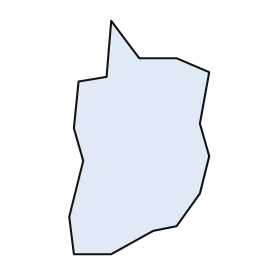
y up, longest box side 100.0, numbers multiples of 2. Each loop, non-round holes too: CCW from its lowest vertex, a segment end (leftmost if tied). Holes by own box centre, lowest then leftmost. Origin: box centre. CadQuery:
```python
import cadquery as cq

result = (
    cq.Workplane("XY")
    .moveTo(-28.0, -50.0)
    .lineTo(-12.0, -50.0)
    .lineTo(6.0, -40.0)
    .lineTo(16.0, -38.0)
    .lineTo(26.0, -24.0)
    .lineTo(30.0, -8.0)
    .lineTo(26.0, 6.0)
    .lineTo(30.0, 28.0)
    .lineTo(16.0, 34.0)
    .lineTo(0.0, 34.0)
    .lineTo(-12.0, 50.0)
    .lineTo(-14.0, 26.0)
    .lineTo(-26.0, 24.0)
    .lineTo(-28.0, 4.0)
    .lineTo(-24.0, -10.0)
    .lineTo(-30.0, -34.0)
    .close()
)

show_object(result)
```